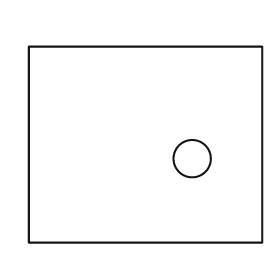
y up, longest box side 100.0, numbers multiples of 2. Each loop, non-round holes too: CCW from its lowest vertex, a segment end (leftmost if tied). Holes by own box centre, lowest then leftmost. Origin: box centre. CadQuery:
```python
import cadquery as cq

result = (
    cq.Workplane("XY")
    .moveTo(-50.0, -42.0)
    .lineTo(50.0, -42.0)
    .lineTo(50.0, 42.0)
    .lineTo(-50.0, 42.0)
    .close()
    .moveTo(20.0, -6.0)
    .circle(8.0)
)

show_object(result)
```